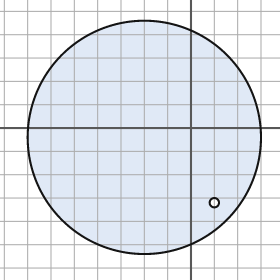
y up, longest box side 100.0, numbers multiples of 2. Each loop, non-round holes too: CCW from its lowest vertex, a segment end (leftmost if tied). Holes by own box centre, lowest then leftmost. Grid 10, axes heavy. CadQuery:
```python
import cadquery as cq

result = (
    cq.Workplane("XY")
    .moveTo(-20.0, -4.0)
    .circle(50.0)
    .moveTo(10.0, -32.0)
    .circle(2.0)
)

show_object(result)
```